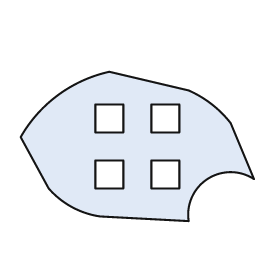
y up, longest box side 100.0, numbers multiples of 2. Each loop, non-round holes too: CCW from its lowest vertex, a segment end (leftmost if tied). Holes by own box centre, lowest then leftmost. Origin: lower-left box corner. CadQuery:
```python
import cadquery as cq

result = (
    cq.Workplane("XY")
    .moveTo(72.0, 0.0)
    .threePointArc((80.0, 18.0), (100.0, 18.0))
    .lineTo(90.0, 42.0)
    .threePointArc((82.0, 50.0), (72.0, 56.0))
    .lineTo(38.0, 64.0)
    .threePointArc((16.0, 54.0), (0.0, 36.0))
    .lineTo(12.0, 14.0)
    .threePointArc((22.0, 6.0), (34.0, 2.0))
    .close()
    .moveTo(32.0, 14.0)
    .lineTo(44.0, 14.0)
    .lineTo(44.0, 26.0)
    .lineTo(32.0, 26.0)
    .close()
    .moveTo(56.0, 14.0)
    .lineTo(68.0, 14.0)
    .lineTo(68.0, 26.0)
    .lineTo(56.0, 26.0)
    .close()
    .moveTo(32.0, 38.0)
    .lineTo(44.0, 38.0)
    .lineTo(44.0, 50.0)
    .lineTo(32.0, 50.0)
    .close()
    .moveTo(56.0, 38.0)
    .lineTo(68.0, 38.0)
    .lineTo(68.0, 50.0)
    .lineTo(56.0, 50.0)
    .close()
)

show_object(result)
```